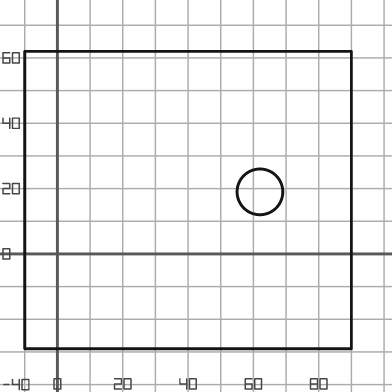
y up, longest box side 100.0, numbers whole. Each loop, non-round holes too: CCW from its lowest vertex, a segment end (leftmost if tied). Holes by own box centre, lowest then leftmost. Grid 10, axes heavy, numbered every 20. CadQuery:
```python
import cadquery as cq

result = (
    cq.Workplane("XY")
    .moveTo(-10.0, -29.0)
    .lineTo(90.0, -29.0)
    .lineTo(90.0, 62.0)
    .lineTo(-10.0, 62.0)
    .close()
    .moveTo(62.0, 19.0)
    .circle(7.0)
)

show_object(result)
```